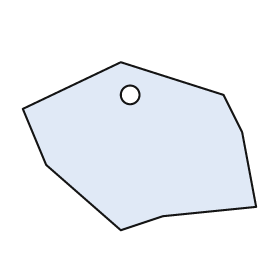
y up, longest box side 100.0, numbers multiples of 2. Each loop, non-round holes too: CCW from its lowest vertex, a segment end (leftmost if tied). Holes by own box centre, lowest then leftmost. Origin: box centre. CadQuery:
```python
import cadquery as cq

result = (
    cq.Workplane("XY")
    .moveTo(-8.0, -36.0)
    .lineTo(10.0, -30.0)
    .lineTo(50.0, -26.0)
    .lineTo(44.0, 6.0)
    .lineTo(36.0, 22.0)
    .lineTo(-8.0, 36.0)
    .lineTo(-50.0, 16.0)
    .lineTo(-40.0, -8.0)
    .close()
    .moveTo(-4.0, 22.0)
    .circle(4.0)
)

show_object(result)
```